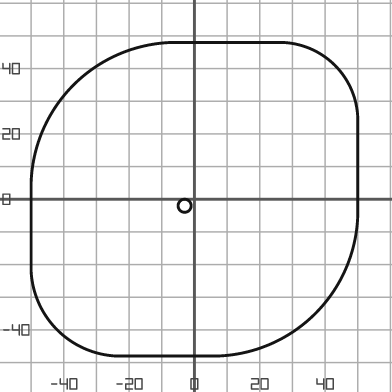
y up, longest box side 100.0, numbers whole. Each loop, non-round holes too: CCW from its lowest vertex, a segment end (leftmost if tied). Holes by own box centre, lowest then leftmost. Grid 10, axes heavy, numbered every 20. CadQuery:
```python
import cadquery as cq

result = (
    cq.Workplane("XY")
    .moveTo(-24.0, -48.0)
    .lineTo(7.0, -48.0)
    .threePointArc((37.0, -35.0), (50.0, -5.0))
    .lineTo(50.0, 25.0)
    .threePointArc((43.0, 41.0), (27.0, 48.0))
    .lineTo(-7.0, 48.0)
    .threePointArc((-37.0, 35.0), (-50.0, 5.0))
    .lineTo(-50.0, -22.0)
    .threePointArc((-42.0, -40.0), (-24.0, -48.0))
    .close()
    .moveTo(-3.0, -2.0)
    .circle(2.0)
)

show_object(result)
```